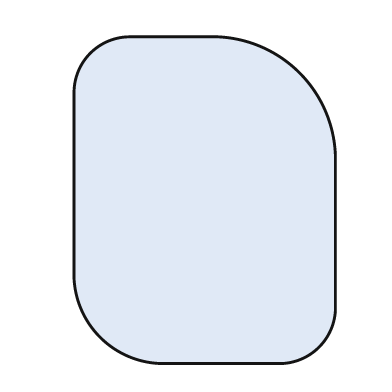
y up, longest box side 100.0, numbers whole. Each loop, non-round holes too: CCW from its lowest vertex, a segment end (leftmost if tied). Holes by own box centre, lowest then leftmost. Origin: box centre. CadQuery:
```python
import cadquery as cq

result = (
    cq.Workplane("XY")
    .moveTo(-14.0, -50.0)
    .lineTo(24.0, -50.0)
    .threePointArc((35.0, -45.0), (40.0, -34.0))
    .lineTo(40.0, 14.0)
    .threePointArc((29.0, 39.0), (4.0, 50.0))
    .lineTo(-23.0, 50.0)
    .threePointArc((-35.0, 45.0), (-40.0, 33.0))
    .lineTo(-40.0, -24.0)
    .threePointArc((-32.0, -42.0), (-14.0, -50.0))
    .close()
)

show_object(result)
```